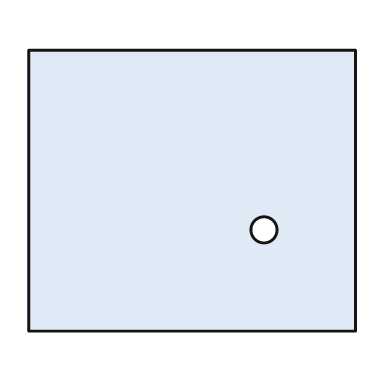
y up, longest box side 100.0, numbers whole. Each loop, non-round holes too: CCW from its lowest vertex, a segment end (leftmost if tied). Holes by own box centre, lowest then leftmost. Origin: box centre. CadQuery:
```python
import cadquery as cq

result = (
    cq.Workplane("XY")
    .moveTo(-50.0, -43.0)
    .lineTo(50.0, -43.0)
    .lineTo(50.0, 43.0)
    .lineTo(-50.0, 43.0)
    .close()
    .moveTo(22.0, -12.0)
    .circle(4.0)
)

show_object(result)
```